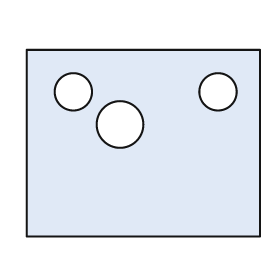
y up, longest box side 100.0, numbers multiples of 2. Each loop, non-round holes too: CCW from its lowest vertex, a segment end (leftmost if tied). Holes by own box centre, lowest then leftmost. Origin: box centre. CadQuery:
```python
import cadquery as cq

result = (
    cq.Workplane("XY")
    .moveTo(-50.0, -40.0)
    .lineTo(50.0, -40.0)
    .lineTo(50.0, 40.0)
    .lineTo(-50.0, 40.0)
    .close()
    .moveTo(-10.0, 8.0)
    .circle(10.0)
    .moveTo(-30.0, 22.0)
    .circle(8.0)
    .moveTo(32.0, 22.0)
    .circle(8.0)
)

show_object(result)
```